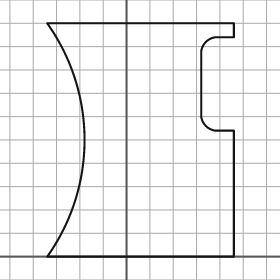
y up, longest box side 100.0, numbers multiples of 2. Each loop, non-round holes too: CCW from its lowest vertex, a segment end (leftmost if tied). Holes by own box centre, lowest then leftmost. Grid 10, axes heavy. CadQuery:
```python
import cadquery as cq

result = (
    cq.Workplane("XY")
    .moveTo(-34.0, 0.0)
    .lineTo(46.0, 0.0)
    .lineTo(46.0, 54.0)
    .lineTo(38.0, 54.0)
    .threePointArc((34.0, 56.0), (32.0, 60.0))
    .lineTo(32.0, 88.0)
    .threePointArc((34.0, 92.0), (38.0, 94.0))
    .lineTo(46.0, 94.0)
    .lineTo(46.0, 100.0)
    .lineTo(-34.0, 100.0)
    .threePointArc((-18.0, 50.0), (-34.0, 0.0))
    .close()
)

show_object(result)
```